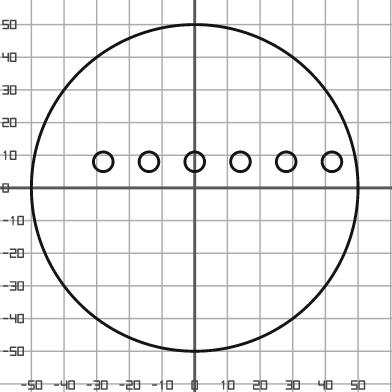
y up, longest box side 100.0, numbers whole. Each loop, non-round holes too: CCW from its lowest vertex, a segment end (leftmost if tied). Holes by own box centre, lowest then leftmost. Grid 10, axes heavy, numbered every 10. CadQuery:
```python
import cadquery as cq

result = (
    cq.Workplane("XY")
    .moveTo(0.0, 0.0)
    .circle(50.0)
    .moveTo(-28.0, 8.0)
    .circle(3.0)
    .moveTo(-14.0, 8.0)
    .circle(3.0)
    .moveTo(0.0, 8.0)
    .circle(3.0)
    .moveTo(14.0, 8.0)
    .circle(3.0)
    .moveTo(28.0, 8.0)
    .circle(3.0)
    .moveTo(42.0, 8.0)
    .circle(3.0)
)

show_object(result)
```